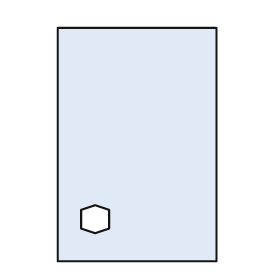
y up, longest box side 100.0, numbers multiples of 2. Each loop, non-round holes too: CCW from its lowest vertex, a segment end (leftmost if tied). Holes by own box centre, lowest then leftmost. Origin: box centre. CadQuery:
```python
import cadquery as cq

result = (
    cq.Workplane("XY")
    .moveTo(-34.0, -50.0)
    .lineTo(34.0, -50.0)
    .lineTo(34.0, 50.0)
    .lineTo(-34.0, 50.0)
    .close()
    .moveTo(-18.0, -38.0)
    .lineTo(-12.0, -36.0)
    .lineTo(-12.0, -28.0)
    .lineTo(-18.0, -26.0)
    .lineTo(-24.0, -28.0)
    .lineTo(-24.0, -36.0)
    .close()
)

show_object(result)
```